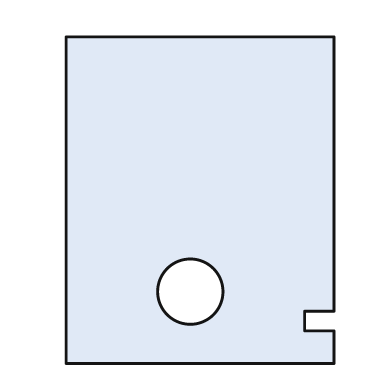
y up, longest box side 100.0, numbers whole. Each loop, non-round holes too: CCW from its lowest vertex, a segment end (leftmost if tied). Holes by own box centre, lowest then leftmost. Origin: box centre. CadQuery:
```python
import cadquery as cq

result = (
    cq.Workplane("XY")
    .moveTo(-41.0, -50.0)
    .lineTo(41.0, -50.0)
    .lineTo(41.0, -40.0)
    .lineTo(32.0, -40.0)
    .lineTo(32.0, -34.0)
    .lineTo(41.0, -34.0)
    .lineTo(41.0, 50.0)
    .lineTo(-41.0, 50.0)
    .close()
    .moveTo(-3.0, -28.0)
    .circle(10.0)
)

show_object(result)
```